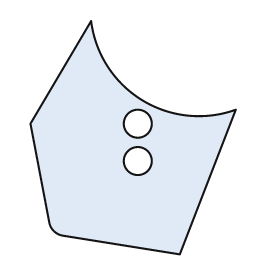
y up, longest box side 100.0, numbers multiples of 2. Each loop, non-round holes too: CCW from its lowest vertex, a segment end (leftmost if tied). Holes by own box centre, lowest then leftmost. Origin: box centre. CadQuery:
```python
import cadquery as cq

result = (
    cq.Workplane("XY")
    .moveTo(20.0, -50.0)
    .lineTo(44.0, 12.0)
    .threePointArc((4.0, 16.0), (-18.0, 50.0))
    .lineTo(-44.0, 6.0)
    .lineTo(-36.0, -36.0)
    .threePointArc((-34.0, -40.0), (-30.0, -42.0))
    .close()
    .moveTo(2.0, -10.0)
    .circle(6.0)
    .moveTo(2.0, 6.0)
    .circle(6.0)
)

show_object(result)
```